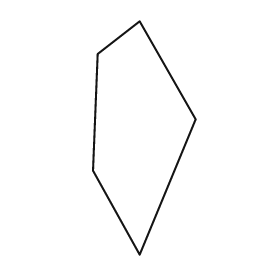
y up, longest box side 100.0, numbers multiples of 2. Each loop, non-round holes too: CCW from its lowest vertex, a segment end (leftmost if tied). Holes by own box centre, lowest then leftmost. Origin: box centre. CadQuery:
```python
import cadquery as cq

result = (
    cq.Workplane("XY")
    .moveTo(-2.0, -50.0)
    .lineTo(22.0, 8.0)
    .lineTo(-2.0, 50.0)
    .lineTo(-20.0, 36.0)
    .lineTo(-22.0, -14.0)
    .close()
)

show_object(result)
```